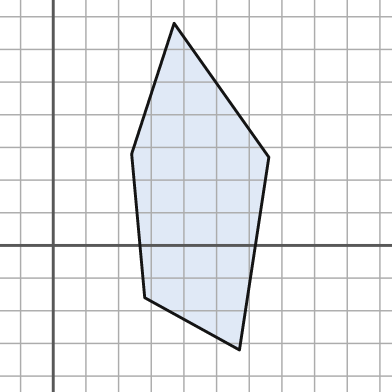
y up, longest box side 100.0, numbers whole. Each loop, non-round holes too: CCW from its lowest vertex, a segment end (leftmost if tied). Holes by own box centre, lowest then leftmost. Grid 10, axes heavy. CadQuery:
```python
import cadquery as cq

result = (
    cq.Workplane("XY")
    .moveTo(57.0, -32.0)
    .lineTo(66.0, 27.0)
    .lineTo(37.0, 68.0)
    .lineTo(24.0, 28.0)
    .lineTo(28.0, -16.0)
    .close()
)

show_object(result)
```